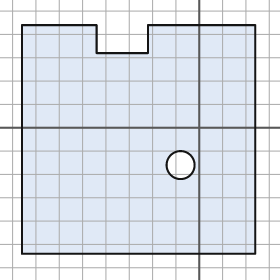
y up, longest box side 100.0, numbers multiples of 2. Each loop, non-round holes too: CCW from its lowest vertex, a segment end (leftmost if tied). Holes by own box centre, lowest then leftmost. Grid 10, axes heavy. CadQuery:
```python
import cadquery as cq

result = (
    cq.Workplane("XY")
    .moveTo(-76.0, -54.0)
    .lineTo(24.0, -54.0)
    .lineTo(24.0, 44.0)
    .lineTo(-22.0, 44.0)
    .lineTo(-22.0, 32.0)
    .lineTo(-44.0, 32.0)
    .lineTo(-44.0, 44.0)
    .lineTo(-76.0, 44.0)
    .close()
    .moveTo(-8.0, -16.0)
    .circle(6.0)
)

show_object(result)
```